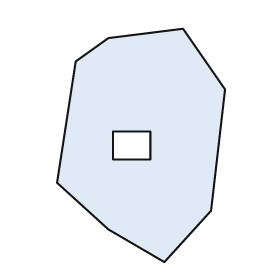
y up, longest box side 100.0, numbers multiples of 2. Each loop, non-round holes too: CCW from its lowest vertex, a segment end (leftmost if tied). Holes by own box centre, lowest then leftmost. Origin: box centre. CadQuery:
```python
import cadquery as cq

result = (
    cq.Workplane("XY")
    .moveTo(10.0, -50.0)
    .lineTo(30.0, -28.0)
    .lineTo(36.0, 24.0)
    .lineTo(18.0, 50.0)
    .lineTo(-14.0, 46.0)
    .lineTo(-28.0, 36.0)
    .lineTo(-36.0, -16.0)
    .lineTo(-14.0, -36.0)
    .close()
    .moveTo(-12.0, -6.0)
    .lineTo(4.0, -6.0)
    .lineTo(4.0, 6.0)
    .lineTo(-12.0, 6.0)
    .close()
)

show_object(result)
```